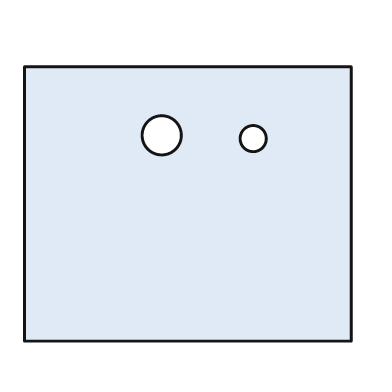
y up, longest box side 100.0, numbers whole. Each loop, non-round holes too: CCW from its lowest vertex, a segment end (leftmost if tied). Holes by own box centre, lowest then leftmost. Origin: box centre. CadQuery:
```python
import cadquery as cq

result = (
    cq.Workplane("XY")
    .moveTo(-50.0, -42.0)
    .lineTo(50.0, -42.0)
    .lineTo(50.0, 42.0)
    .lineTo(-50.0, 42.0)
    .close()
    .moveTo(20.0, 20.0)
    .circle(4.0)
    .moveTo(-8.0, 21.0)
    .circle(6.0)
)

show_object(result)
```